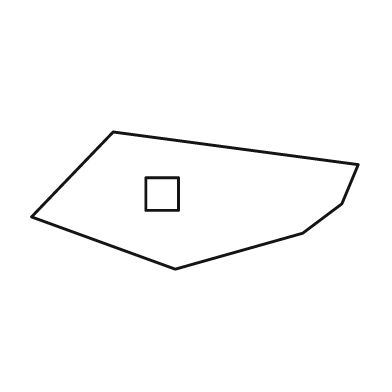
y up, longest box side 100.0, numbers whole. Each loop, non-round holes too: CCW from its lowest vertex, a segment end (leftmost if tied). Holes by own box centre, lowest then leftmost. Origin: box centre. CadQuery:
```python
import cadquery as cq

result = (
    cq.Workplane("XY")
    .moveTo(-6.0, -21.0)
    .lineTo(33.0, -10.0)
    .lineTo(45.0, -1.0)
    .lineTo(50.0, 11.0)
    .lineTo(-25.0, 21.0)
    .lineTo(-50.0, -5.0)
    .close()
    .moveTo(-15.0, -3.0)
    .lineTo(-5.0, -3.0)
    .lineTo(-5.0, 7.0)
    .lineTo(-15.0, 7.0)
    .close()
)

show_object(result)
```